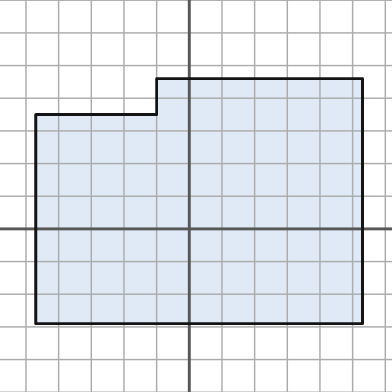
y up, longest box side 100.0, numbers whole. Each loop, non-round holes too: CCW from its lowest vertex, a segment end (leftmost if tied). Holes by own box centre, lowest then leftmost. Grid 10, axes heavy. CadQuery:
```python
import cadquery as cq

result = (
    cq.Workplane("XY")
    .moveTo(-47.0, -29.0)
    .lineTo(53.0, -29.0)
    .lineTo(53.0, 46.0)
    .lineTo(-10.0, 46.0)
    .lineTo(-10.0, 35.0)
    .lineTo(-47.0, 35.0)
    .close()
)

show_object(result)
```